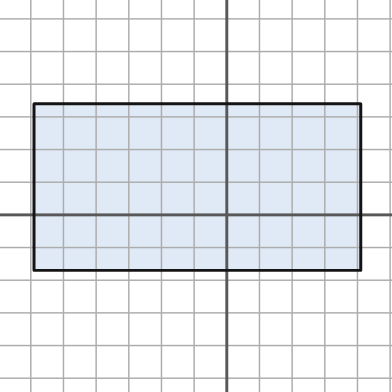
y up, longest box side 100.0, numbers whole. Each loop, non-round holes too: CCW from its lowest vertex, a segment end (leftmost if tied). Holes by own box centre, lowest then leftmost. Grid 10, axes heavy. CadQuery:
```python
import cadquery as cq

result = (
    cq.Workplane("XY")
    .moveTo(-59.0, -17.0)
    .lineTo(41.0, -17.0)
    .lineTo(41.0, 34.0)
    .lineTo(-59.0, 34.0)
    .close()
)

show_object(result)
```